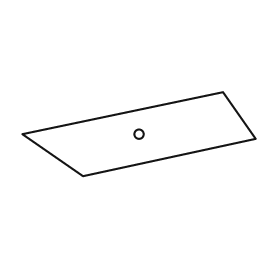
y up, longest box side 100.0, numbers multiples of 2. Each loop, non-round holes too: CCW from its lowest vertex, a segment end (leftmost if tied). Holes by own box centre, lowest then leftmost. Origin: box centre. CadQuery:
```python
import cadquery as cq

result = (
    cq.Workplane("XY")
    .moveTo(-24.0, -18.0)
    .lineTo(50.0, -2.0)
    .lineTo(36.0, 18.0)
    .lineTo(-50.0, 0.0)
    .close()
    .moveTo(0.0, 0.0)
    .circle(2.0)
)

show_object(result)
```